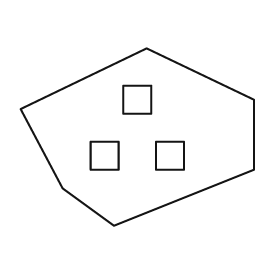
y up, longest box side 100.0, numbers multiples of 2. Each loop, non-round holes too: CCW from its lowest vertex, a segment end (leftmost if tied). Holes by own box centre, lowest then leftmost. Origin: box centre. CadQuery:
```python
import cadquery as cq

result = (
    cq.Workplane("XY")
    .moveTo(-10.0, -38.0)
    .lineTo(50.0, -14.0)
    .lineTo(50.0, 16.0)
    .lineTo(4.0, 38.0)
    .lineTo(-50.0, 12.0)
    .lineTo(-32.0, -22.0)
    .close()
    .moveTo(-20.0, -14.0)
    .lineTo(-8.0, -14.0)
    .lineTo(-8.0, -2.0)
    .lineTo(-20.0, -2.0)
    .close()
    .moveTo(8.0, -14.0)
    .lineTo(20.0, -14.0)
    .lineTo(20.0, -2.0)
    .lineTo(8.0, -2.0)
    .close()
    .moveTo(-6.0, 10.0)
    .lineTo(6.0, 10.0)
    .lineTo(6.0, 22.0)
    .lineTo(-6.0, 22.0)
    .close()
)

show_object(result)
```